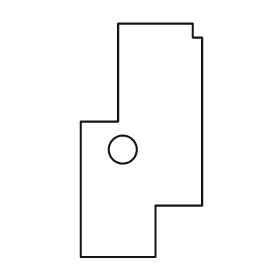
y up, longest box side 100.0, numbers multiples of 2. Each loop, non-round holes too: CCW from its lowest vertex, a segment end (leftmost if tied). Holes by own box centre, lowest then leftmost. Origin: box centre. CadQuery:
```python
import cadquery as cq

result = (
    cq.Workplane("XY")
    .moveTo(-26.0, -50.0)
    .lineTo(6.0, -50.0)
    .lineTo(6.0, -28.0)
    .lineTo(26.0, -28.0)
    .lineTo(26.0, 44.0)
    .lineTo(22.0, 44.0)
    .lineTo(22.0, 50.0)
    .lineTo(-10.0, 50.0)
    .lineTo(-10.0, 8.0)
    .lineTo(-26.0, 8.0)
    .close()
    .moveTo(-8.0, -4.0)
    .circle(6.0)
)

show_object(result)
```